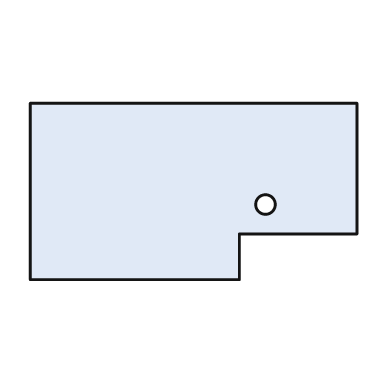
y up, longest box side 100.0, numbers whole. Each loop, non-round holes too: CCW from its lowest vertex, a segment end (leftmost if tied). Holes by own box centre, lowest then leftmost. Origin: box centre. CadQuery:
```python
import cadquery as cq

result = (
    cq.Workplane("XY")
    .moveTo(-50.0, -27.0)
    .lineTo(14.0, -27.0)
    .lineTo(14.0, -13.0)
    .lineTo(50.0, -13.0)
    .lineTo(50.0, 27.0)
    .lineTo(-50.0, 27.0)
    .close()
    .moveTo(22.0, -4.0)
    .circle(3.0)
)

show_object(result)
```